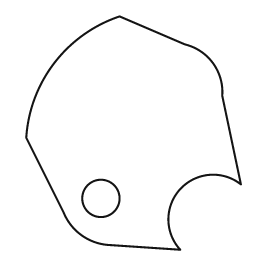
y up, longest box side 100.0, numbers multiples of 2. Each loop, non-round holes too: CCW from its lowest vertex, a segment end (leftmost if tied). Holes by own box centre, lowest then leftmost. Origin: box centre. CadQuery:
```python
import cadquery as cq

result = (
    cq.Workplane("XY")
    .moveTo(20.0, -50.0)
    .threePointArc((20.0, -24.0), (46.0, -22.0))
    .lineTo(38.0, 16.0)
    .threePointArc((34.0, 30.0), (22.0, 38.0))
    .lineTo(-6.0, 50.0)
    .threePointArc((-34.0, 30.0), (-46.0, -2.0))
    .lineTo(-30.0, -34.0)
    .threePointArc((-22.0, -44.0), (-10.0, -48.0))
    .close()
    .moveTo(-14.0, -28.0)
    .circle(8.0)
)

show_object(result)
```